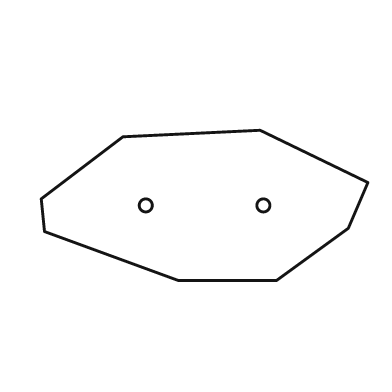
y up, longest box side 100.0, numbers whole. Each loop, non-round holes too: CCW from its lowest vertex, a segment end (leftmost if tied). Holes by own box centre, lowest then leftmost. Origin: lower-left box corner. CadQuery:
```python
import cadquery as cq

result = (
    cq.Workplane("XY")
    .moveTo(42.0, 0.0)
    .lineTo(72.0, 0.0)
    .lineTo(94.0, 16.0)
    .lineTo(100.0, 30.0)
    .lineTo(67.0, 46.0)
    .lineTo(25.0, 44.0)
    .lineTo(0.0, 25.0)
    .lineTo(1.0, 15.0)
    .close()
    .moveTo(32.0, 23.0)
    .circle(2.0)
    .moveTo(68.0, 23.0)
    .circle(2.0)
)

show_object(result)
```